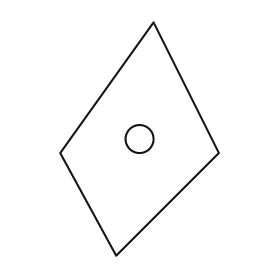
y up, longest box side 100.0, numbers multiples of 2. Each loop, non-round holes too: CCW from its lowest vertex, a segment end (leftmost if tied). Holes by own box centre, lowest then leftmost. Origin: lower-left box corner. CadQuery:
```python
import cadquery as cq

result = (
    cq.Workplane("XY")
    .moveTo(24.0, 0.0)
    .lineTo(68.0, 44.0)
    .lineTo(40.0, 100.0)
    .lineTo(0.0, 44.0)
    .close()
    .moveTo(34.0, 50.0)
    .circle(6.0)
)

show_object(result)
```